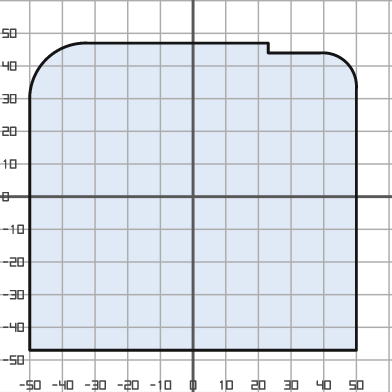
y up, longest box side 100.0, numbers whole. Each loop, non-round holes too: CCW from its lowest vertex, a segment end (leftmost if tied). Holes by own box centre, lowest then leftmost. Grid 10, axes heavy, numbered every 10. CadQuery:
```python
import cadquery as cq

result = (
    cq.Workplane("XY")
    .moveTo(-50.0, -47.0)
    .lineTo(50.0, -47.0)
    .lineTo(50.0, 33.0)
    .threePointArc((47.0, 41.0), (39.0, 44.0))
    .lineTo(23.0, 44.0)
    .lineTo(23.0, 47.0)
    .lineTo(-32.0, 47.0)
    .threePointArc((-45.0, 42.0), (-50.0, 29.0))
    .close()
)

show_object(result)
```